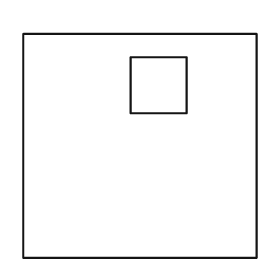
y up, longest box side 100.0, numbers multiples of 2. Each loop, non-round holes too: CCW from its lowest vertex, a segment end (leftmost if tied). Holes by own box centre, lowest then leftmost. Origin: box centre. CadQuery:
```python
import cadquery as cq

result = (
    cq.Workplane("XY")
    .moveTo(-50.0, -48.0)
    .lineTo(50.0, -48.0)
    .lineTo(50.0, 48.0)
    .lineTo(-50.0, 48.0)
    .close()
    .moveTo(-4.0, 14.0)
    .lineTo(20.0, 14.0)
    .lineTo(20.0, 38.0)
    .lineTo(-4.0, 38.0)
    .close()
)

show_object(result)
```